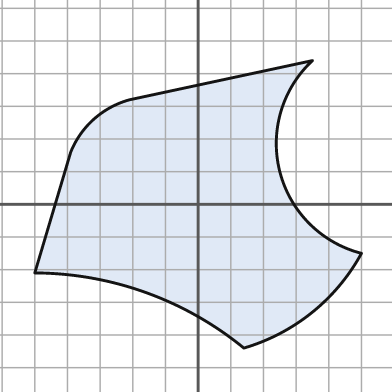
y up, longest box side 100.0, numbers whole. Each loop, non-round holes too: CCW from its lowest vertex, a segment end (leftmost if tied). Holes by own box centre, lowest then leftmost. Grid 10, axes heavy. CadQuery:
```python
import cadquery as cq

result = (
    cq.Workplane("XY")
    .moveTo(14.0, -44.0)
    .threePointArc((35.0, -33.0), (50.0, -15.0))
    .threePointArc((25.0, 10.0), (35.0, 44.0))
    .lineTo(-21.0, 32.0)
    .threePointArc((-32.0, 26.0), (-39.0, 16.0))
    .lineTo(-50.0, -21.0)
    .threePointArc((-16.0, -27.0), (14.0, -44.0))
    .close()
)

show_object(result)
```